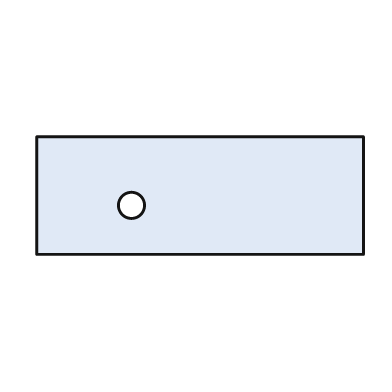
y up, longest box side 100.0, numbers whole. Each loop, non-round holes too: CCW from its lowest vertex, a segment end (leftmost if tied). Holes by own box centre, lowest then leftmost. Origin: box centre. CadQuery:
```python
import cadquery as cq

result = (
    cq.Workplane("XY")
    .moveTo(-50.0, -18.0)
    .lineTo(50.0, -18.0)
    .lineTo(50.0, 18.0)
    .lineTo(-50.0, 18.0)
    .close()
    .moveTo(-21.0, -3.0)
    .circle(4.0)
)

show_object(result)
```